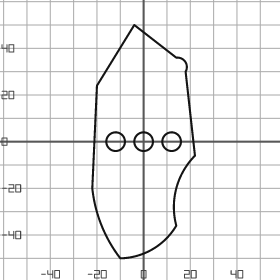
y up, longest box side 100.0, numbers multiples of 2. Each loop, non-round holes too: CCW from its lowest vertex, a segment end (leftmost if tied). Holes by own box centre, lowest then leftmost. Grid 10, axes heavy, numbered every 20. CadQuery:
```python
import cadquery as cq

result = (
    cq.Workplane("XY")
    .moveTo(-10.0, -50.0)
    .threePointArc((4.0, -46.0), (14.0, -36.0))
    .threePointArc((14.0, -20.0), (22.0, -6.0))
    .lineTo(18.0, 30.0)
    .threePointArc((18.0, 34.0), (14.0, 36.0))
    .lineTo(-4.0, 50.0)
    .lineTo(-20.0, 24.0)
    .lineTo(-22.0, -20.0)
    .threePointArc((-18.0, -36.0), (-10.0, -50.0))
    .close()
    .moveTo(-12.0, 0.0)
    .circle(4.0)
    .moveTo(0.0, 0.0)
    .circle(4.0)
    .moveTo(12.0, 0.0)
    .circle(4.0)
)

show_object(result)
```